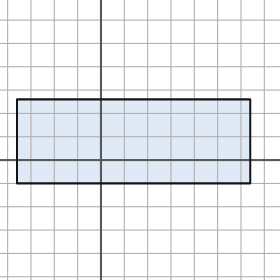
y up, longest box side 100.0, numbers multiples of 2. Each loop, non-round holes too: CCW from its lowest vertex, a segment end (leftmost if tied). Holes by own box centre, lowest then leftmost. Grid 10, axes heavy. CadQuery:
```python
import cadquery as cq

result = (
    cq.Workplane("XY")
    .moveTo(-36.0, -10.0)
    .lineTo(64.0, -10.0)
    .lineTo(64.0, 26.0)
    .lineTo(-36.0, 26.0)
    .close()
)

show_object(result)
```